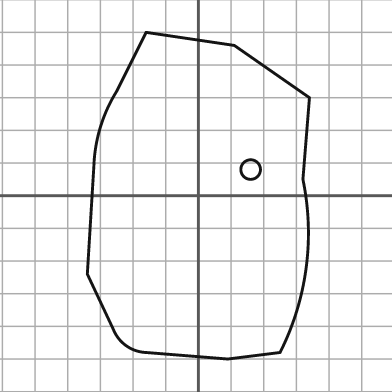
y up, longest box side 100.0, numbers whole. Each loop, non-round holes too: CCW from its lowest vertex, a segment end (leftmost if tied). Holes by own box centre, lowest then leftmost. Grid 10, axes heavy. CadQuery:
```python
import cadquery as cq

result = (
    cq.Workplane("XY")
    .moveTo(9.0, -50.0)
    .lineTo(25.0, -48.0)
    .threePointArc((33.0, -22.0), (32.0, 5.0))
    .lineTo(34.0, 30.0)
    .lineTo(11.0, 46.0)
    .lineTo(-16.0, 50.0)
    .lineTo(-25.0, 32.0)
    .threePointArc((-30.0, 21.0), (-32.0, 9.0))
    .lineTo(-34.0, -24.0)
    .lineTo(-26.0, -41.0)
    .threePointArc((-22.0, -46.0), (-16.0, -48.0))
    .close()
    .moveTo(16.0, 8.0)
    .circle(3.0)
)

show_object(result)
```